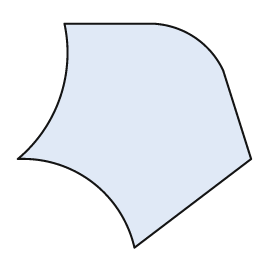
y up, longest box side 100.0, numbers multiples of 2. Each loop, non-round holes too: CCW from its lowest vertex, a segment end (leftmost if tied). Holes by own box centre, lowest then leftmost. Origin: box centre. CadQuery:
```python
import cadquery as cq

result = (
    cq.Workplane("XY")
    .moveTo(0.0, -48.0)
    .lineTo(50.0, -10.0)
    .lineTo(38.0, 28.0)
    .threePointArc((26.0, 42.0), (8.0, 48.0))
    .lineTo(-30.0, 48.0)
    .threePointArc((-32.0, 16.0), (-50.0, -10.0))
    .threePointArc((-18.0, -20.0), (0.0, -48.0))
    .close()
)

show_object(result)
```